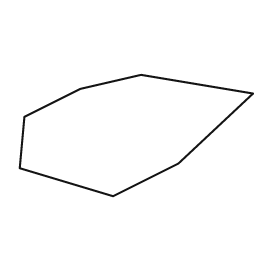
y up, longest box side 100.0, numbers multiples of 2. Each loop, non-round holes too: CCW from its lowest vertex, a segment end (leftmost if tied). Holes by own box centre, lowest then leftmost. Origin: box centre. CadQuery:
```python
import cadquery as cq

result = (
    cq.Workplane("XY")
    .moveTo(-10.0, -26.0)
    .lineTo(18.0, -12.0)
    .lineTo(50.0, 18.0)
    .lineTo(2.0, 26.0)
    .lineTo(-24.0, 20.0)
    .lineTo(-48.0, 8.0)
    .lineTo(-50.0, -14.0)
    .close()
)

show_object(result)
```